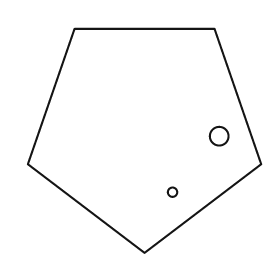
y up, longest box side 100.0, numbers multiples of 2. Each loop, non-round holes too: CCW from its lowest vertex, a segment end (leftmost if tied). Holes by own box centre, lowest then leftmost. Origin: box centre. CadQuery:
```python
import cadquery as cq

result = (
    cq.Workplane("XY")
    .moveTo(0.0, -48.0)
    .lineTo(50.0, -10.0)
    .lineTo(30.0, 48.0)
    .lineTo(-30.0, 48.0)
    .lineTo(-50.0, -10.0)
    .close()
    .moveTo(12.0, -22.0)
    .circle(2.0)
    .moveTo(32.0, 2.0)
    .circle(4.0)
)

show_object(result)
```